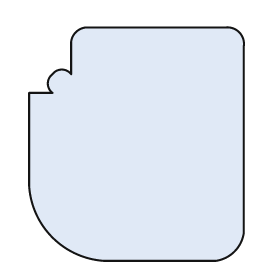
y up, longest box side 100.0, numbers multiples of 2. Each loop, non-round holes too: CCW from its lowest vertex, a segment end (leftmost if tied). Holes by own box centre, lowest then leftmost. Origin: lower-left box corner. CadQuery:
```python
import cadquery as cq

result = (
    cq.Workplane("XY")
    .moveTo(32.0, 0.0)
    .lineTo(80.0, 0.0)
    .threePointArc((88.0, 4.0), (92.0, 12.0))
    .lineTo(92.0, 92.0)
    .threePointArc((90.0, 98.0), (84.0, 100.0))
    .lineTo(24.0, 100.0)
    .threePointArc((20.0, 98.0), (18.0, 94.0))
    .lineTo(18.0, 80.0)
    .threePointArc((14.0, 82.0), (10.0, 80.0))
    .threePointArc((8.0, 76.0), (10.0, 72.0))
    .lineTo(0.0, 72.0)
    .lineTo(0.0, 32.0)
    .threePointArc((10.0, 10.0), (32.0, 0.0))
    .close()
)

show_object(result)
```